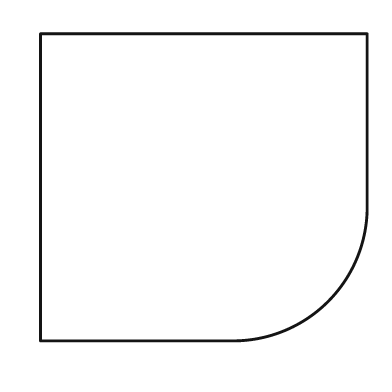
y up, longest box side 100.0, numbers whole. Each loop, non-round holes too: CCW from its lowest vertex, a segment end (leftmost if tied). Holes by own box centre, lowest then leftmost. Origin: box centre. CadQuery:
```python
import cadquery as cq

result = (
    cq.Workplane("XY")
    .moveTo(-50.0, -47.0)
    .lineTo(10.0, -47.0)
    .threePointArc((38.0, -35.0), (50.0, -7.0))
    .lineTo(50.0, 47.0)
    .lineTo(-50.0, 47.0)
    .close()
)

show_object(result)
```